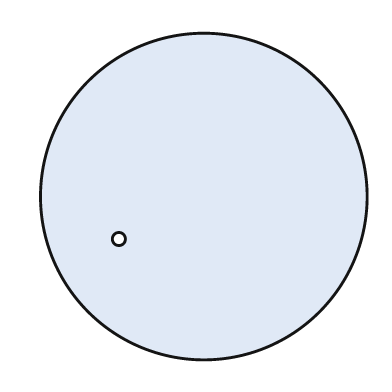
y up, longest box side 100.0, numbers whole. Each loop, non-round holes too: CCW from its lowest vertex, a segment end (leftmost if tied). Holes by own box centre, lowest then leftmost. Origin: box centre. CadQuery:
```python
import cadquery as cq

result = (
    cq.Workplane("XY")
    .moveTo(0.0, 0.0)
    .circle(50.0)
    .moveTo(-26.0, -13.0)
    .circle(2.0)
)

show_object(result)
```